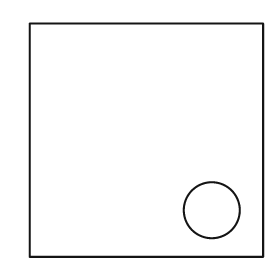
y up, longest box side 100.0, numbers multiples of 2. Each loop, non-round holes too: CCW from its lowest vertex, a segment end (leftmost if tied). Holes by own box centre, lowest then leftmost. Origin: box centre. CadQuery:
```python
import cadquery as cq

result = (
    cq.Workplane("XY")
    .moveTo(-50.0, -50.0)
    .lineTo(50.0, -50.0)
    .lineTo(50.0, 50.0)
    .lineTo(-50.0, 50.0)
    .close()
    .moveTo(28.0, -30.0)
    .circle(12.0)
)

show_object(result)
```